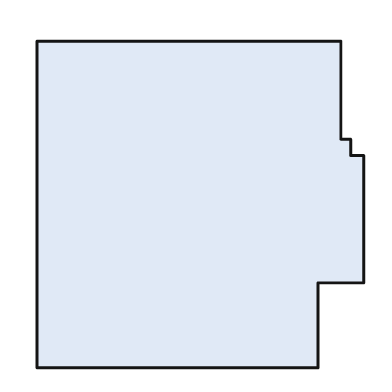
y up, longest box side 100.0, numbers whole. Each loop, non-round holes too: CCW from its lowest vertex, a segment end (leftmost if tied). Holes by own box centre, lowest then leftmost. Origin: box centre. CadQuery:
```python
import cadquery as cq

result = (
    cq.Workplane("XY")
    .moveTo(-50.0, -50.0)
    .lineTo(36.0, -50.0)
    .lineTo(36.0, -24.0)
    .lineTo(50.0, -24.0)
    .lineTo(50.0, 15.0)
    .lineTo(46.0, 15.0)
    .lineTo(46.0, 20.0)
    .lineTo(43.0, 20.0)
    .lineTo(43.0, 50.0)
    .lineTo(-50.0, 50.0)
    .close()
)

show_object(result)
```